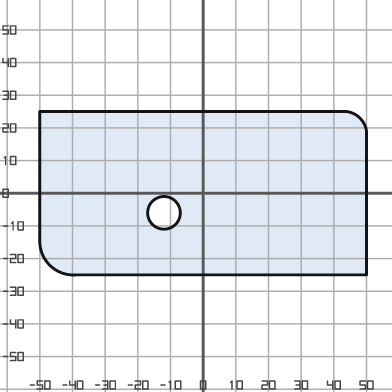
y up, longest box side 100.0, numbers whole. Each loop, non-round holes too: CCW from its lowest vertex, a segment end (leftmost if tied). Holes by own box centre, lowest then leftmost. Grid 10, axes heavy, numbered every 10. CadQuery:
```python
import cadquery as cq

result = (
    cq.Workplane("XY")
    .moveTo(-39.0, -25.0)
    .lineTo(50.0, -25.0)
    .lineTo(50.0, 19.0)
    .threePointArc((48.0, 23.0), (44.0, 25.0))
    .lineTo(-50.0, 25.0)
    .lineTo(-50.0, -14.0)
    .threePointArc((-47.0, -22.0), (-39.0, -25.0))
    .close()
    .moveTo(-12.0, -6.0)
    .circle(5.0)
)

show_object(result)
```